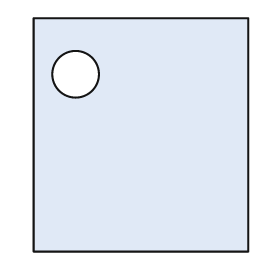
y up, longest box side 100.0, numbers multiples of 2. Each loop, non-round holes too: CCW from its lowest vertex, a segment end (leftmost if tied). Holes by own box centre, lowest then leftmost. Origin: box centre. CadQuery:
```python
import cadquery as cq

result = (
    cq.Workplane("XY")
    .moveTo(-46.0, -50.0)
    .lineTo(46.0, -50.0)
    .lineTo(46.0, 50.0)
    .lineTo(-46.0, 50.0)
    .close()
    .moveTo(-28.0, 26.0)
    .circle(10.0)
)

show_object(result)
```